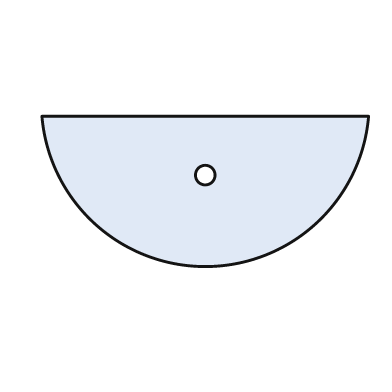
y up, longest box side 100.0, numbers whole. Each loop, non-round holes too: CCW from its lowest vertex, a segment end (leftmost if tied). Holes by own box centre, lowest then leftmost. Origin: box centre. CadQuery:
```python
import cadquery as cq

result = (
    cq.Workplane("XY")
    .moveTo(-50.0, 23.0)
    .threePointArc((0.0, -23.0), (50.0, 23.0))
    .close()
    .moveTo(0.0, 5.0)
    .circle(3.0)
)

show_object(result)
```